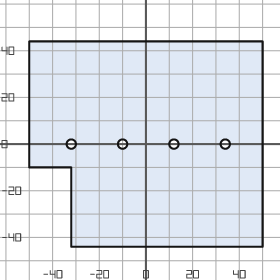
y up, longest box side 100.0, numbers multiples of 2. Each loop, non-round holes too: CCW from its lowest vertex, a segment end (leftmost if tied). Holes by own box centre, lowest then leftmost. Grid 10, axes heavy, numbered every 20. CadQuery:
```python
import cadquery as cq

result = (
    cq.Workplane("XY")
    .moveTo(-32.0, -44.0)
    .lineTo(50.0, -44.0)
    .lineTo(50.0, 44.0)
    .lineTo(-50.0, 44.0)
    .lineTo(-50.0, -10.0)
    .lineTo(-32.0, -10.0)
    .close()
    .moveTo(-32.0, 0.0)
    .circle(2.0)
    .moveTo(-10.0, 0.0)
    .circle(2.0)
    .moveTo(12.0, 0.0)
    .circle(2.0)
    .moveTo(34.0, 0.0)
    .circle(2.0)
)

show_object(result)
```